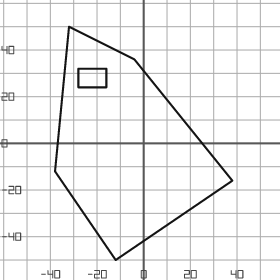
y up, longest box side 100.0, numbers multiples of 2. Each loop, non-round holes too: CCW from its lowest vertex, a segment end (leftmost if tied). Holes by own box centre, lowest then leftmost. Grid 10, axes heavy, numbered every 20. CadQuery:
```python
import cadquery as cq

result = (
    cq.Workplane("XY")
    .moveTo(-12.0, -50.0)
    .lineTo(38.0, -16.0)
    .lineTo(-4.0, 36.0)
    .lineTo(-32.0, 50.0)
    .lineTo(-38.0, -12.0)
    .close()
    .moveTo(-28.0, 24.0)
    .lineTo(-16.0, 24.0)
    .lineTo(-16.0, 32.0)
    .lineTo(-28.0, 32.0)
    .close()
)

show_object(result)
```